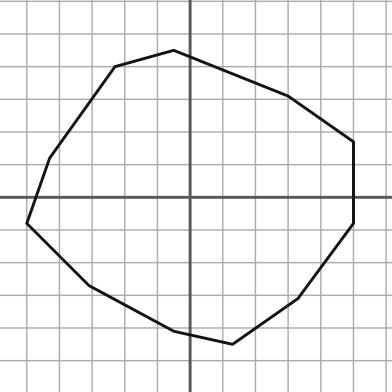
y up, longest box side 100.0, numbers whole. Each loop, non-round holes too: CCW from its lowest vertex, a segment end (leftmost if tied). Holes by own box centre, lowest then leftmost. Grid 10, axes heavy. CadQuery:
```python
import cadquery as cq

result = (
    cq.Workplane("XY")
    .moveTo(13.0, -45.0)
    .lineTo(33.0, -31.0)
    .lineTo(50.0, -8.0)
    .lineTo(50.0, 17.0)
    .lineTo(30.0, 31.0)
    .lineTo(-5.0, 45.0)
    .lineTo(-23.0, 40.0)
    .lineTo(-43.0, 12.0)
    .lineTo(-50.0, -8.0)
    .lineTo(-31.0, -27.0)
    .lineTo(-5.0, -41.0)
    .close()
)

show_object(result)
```